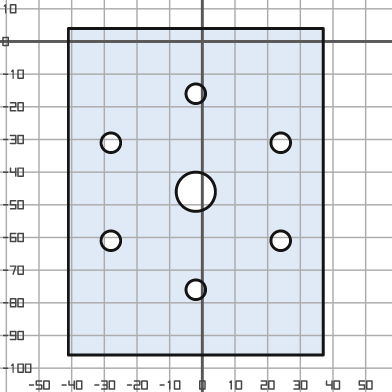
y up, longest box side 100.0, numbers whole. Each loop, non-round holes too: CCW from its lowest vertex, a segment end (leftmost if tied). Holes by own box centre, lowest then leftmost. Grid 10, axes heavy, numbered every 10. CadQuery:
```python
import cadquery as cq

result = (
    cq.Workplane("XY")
    .moveTo(-41.0, -96.0)
    .lineTo(37.0, -96.0)
    .lineTo(37.0, 4.0)
    .lineTo(-41.0, 4.0)
    .close()
    .moveTo(-2.0, -76.0)
    .circle(3.0)
    .moveTo(-28.0, -61.0)
    .circle(3.0)
    .moveTo(24.0, -61.0)
    .circle(3.0)
    .moveTo(-2.0, -46.0)
    .circle(6.0)
    .moveTo(-28.0, -31.0)
    .circle(3.0)
    .moveTo(24.0, -31.0)
    .circle(3.0)
    .moveTo(-2.0, -16.0)
    .circle(3.0)
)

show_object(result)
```